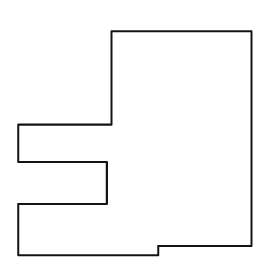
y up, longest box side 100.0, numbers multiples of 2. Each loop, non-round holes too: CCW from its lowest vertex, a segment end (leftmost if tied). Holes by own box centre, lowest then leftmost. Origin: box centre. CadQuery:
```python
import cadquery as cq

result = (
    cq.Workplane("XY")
    .moveTo(-50.0, -48.0)
    .lineTo(10.0, -48.0)
    .lineTo(10.0, -44.0)
    .lineTo(50.0, -44.0)
    .lineTo(50.0, 48.0)
    .lineTo(-10.0, 48.0)
    .lineTo(-10.0, 8.0)
    .lineTo(-50.0, 8.0)
    .lineTo(-50.0, -8.0)
    .lineTo(-12.0, -8.0)
    .lineTo(-12.0, -26.0)
    .lineTo(-50.0, -26.0)
    .close()
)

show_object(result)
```